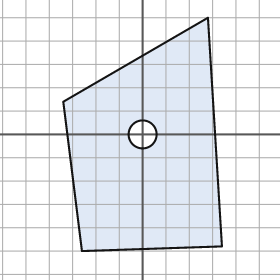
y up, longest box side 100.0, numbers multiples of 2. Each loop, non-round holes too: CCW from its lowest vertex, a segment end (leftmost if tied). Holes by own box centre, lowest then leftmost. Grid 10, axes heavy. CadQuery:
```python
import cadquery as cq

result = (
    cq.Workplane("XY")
    .moveTo(-26.0, -50.0)
    .lineTo(34.0, -48.0)
    .lineTo(28.0, 50.0)
    .lineTo(-34.0, 14.0)
    .close()
    .moveTo(0.0, 0.0)
    .circle(6.0)
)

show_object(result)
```